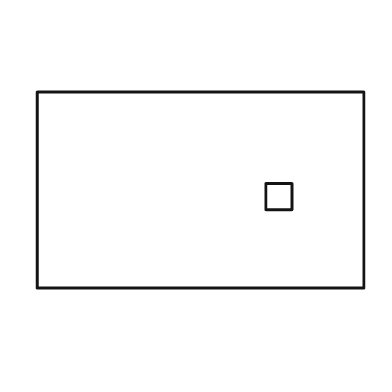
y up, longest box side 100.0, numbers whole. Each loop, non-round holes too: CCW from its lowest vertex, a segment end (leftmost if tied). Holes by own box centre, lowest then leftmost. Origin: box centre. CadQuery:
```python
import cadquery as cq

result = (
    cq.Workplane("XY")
    .moveTo(-50.0, -30.0)
    .lineTo(50.0, -30.0)
    .lineTo(50.0, 30.0)
    .lineTo(-50.0, 30.0)
    .close()
    .moveTo(20.0, -6.0)
    .lineTo(28.0, -6.0)
    .lineTo(28.0, 2.0)
    .lineTo(20.0, 2.0)
    .close()
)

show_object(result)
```